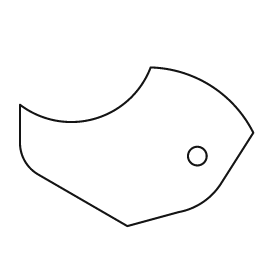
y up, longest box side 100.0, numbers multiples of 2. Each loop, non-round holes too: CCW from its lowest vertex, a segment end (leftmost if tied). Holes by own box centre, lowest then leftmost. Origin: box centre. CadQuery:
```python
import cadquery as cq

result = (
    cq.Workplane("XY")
    .moveTo(-4.0, -34.0)
    .lineTo(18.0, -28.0)
    .threePointArc((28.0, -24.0), (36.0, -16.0))
    .lineTo(50.0, 6.0)
    .threePointArc((32.0, 26.0), (6.0, 34.0))
    .threePointArc((-18.0, 12.0), (-50.0, 18.0))
    .lineTo(-50.0, 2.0)
    .threePointArc((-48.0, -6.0), (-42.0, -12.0))
    .close()
    .moveTo(26.0, -4.0)
    .circle(4.0)
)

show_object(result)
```